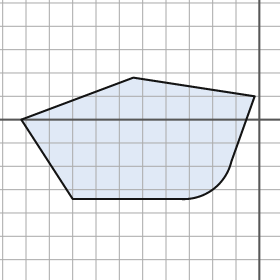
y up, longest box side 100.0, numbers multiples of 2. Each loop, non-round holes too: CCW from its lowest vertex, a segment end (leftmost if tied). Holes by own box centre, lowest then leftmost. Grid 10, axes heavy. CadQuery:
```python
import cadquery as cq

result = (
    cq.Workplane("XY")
    .moveTo(-80.0, -34.0)
    .lineTo(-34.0, -34.0)
    .threePointArc((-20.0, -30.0), (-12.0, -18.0))
    .lineTo(-2.0, 10.0)
    .lineTo(-54.0, 18.0)
    .lineTo(-102.0, 0.0)
    .close()
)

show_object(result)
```